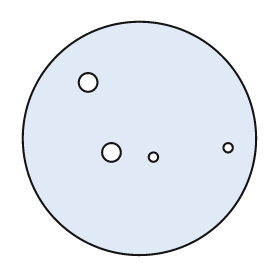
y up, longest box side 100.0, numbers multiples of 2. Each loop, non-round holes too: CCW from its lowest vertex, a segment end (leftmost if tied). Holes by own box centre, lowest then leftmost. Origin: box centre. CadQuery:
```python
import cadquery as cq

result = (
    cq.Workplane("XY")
    .moveTo(0.0, 0.0)
    .circle(50.0)
    .moveTo(6.0, -8.0)
    .circle(2.0)
    .moveTo(-12.0, -6.0)
    .circle(4.0)
    .moveTo(38.0, -4.0)
    .circle(2.0)
    .moveTo(-22.0, 24.0)
    .circle(4.0)
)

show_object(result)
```